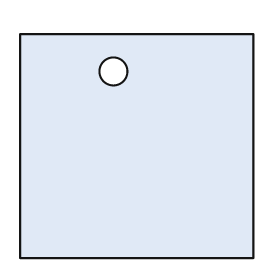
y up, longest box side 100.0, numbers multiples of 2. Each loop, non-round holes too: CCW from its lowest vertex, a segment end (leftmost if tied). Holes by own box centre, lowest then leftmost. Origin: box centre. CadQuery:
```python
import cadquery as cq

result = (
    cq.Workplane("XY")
    .moveTo(-50.0, -48.0)
    .lineTo(50.0, -48.0)
    .lineTo(50.0, 48.0)
    .lineTo(-50.0, 48.0)
    .close()
    .moveTo(-10.0, 32.0)
    .circle(6.0)
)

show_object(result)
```